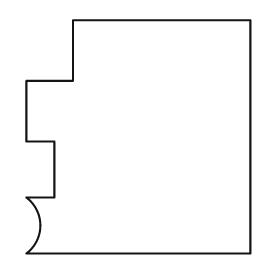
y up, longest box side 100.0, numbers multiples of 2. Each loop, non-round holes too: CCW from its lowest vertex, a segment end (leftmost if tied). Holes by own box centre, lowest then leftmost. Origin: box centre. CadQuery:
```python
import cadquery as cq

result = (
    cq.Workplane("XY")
    .moveTo(-48.0, -50.0)
    .lineTo(48.0, -50.0)
    .lineTo(48.0, 50.0)
    .lineTo(-28.0, 50.0)
    .lineTo(-28.0, 24.0)
    .lineTo(-48.0, 24.0)
    .lineTo(-48.0, -2.0)
    .lineTo(-36.0, -2.0)
    .lineTo(-36.0, -26.0)
    .lineTo(-48.0, -26.0)
    .threePointArc((-42.0, -38.0), (-48.0, -50.0))
    .close()
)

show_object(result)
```